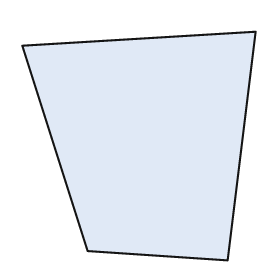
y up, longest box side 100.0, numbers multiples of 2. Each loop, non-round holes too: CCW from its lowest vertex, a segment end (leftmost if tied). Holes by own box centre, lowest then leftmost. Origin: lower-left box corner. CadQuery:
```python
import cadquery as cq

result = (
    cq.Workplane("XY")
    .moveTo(88.0, 0.0)
    .lineTo(100.0, 98.0)
    .lineTo(0.0, 92.0)
    .lineTo(28.0, 4.0)
    .close()
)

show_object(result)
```